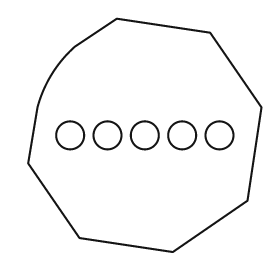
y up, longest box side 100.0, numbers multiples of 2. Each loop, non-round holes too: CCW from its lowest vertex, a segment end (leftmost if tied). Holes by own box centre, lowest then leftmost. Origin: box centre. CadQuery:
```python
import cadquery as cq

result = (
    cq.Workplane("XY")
    .moveTo(12.0, -50.0)
    .lineTo(44.0, -28.0)
    .lineTo(50.0, 12.0)
    .lineTo(28.0, 44.0)
    .lineTo(-12.0, 50.0)
    .lineTo(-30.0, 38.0)
    .threePointArc((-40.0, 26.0), (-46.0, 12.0))
    .lineTo(-50.0, -12.0)
    .lineTo(-28.0, -44.0)
    .close()
    .moveTo(-32.0, 0.0)
    .circle(6.0)
    .moveTo(-16.0, 0.0)
    .circle(6.0)
    .moveTo(0.0, 0.0)
    .circle(6.0)
    .moveTo(16.0, 0.0)
    .circle(6.0)
    .moveTo(32.0, 0.0)
    .circle(6.0)
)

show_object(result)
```